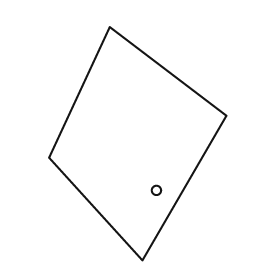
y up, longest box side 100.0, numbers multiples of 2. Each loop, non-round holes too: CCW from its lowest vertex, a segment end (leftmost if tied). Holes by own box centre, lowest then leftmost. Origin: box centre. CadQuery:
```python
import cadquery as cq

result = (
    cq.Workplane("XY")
    .moveTo(2.0, -50.0)
    .lineTo(38.0, 12.0)
    .lineTo(-12.0, 50.0)
    .lineTo(-38.0, -6.0)
    .close()
    .moveTo(8.0, -20.0)
    .circle(2.0)
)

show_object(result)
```